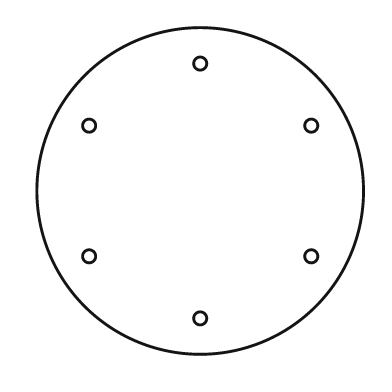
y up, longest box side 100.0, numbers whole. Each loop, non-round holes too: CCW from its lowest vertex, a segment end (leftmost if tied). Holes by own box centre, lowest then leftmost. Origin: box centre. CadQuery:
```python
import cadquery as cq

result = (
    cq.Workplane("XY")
    .moveTo(0.0, 0.0)
    .circle(50.0)
    .moveTo(0.0, -39.0)
    .circle(2.0)
    .moveTo(-34.0, -20.0)
    .circle(2.0)
    .moveTo(34.0, -20.0)
    .circle(2.0)
    .moveTo(-34.0, 20.0)
    .circle(2.0)
    .moveTo(34.0, 20.0)
    .circle(2.0)
    .moveTo(0.0, 39.0)
    .circle(2.0)
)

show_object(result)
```